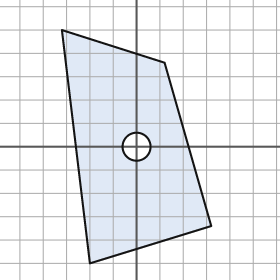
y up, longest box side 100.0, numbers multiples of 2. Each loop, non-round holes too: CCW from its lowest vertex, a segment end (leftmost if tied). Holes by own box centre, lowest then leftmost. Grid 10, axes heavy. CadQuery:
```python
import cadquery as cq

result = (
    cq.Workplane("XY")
    .moveTo(-20.0, -50.0)
    .lineTo(32.0, -34.0)
    .lineTo(12.0, 36.0)
    .lineTo(-32.0, 50.0)
    .close()
    .moveTo(0.0, 0.0)
    .circle(6.0)
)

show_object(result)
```